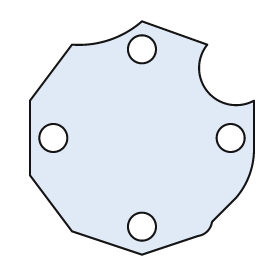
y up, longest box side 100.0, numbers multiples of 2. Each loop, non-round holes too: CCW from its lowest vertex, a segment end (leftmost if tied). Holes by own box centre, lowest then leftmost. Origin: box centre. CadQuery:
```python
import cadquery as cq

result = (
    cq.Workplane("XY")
    .moveTo(0.0, -50.0)
    .lineTo(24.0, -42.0)
    .threePointArc((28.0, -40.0), (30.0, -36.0))
    .lineTo(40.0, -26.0)
    .threePointArc((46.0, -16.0), (48.0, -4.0))
    .lineTo(48.0, 16.0)
    .threePointArc((28.0, 20.0), (28.0, 40.0))
    .lineTo(0.0, 50.0)
    .threePointArc((-14.0, 42.0), (-30.0, 40.0))
    .lineTo(-48.0, 16.0)
    .lineTo(-48.0, -16.0)
    .lineTo(-30.0, -40.0)
    .close()
    .moveTo(0.0, -38.0)
    .circle(6.0)
    .moveTo(-38.0, 0.0)
    .circle(6.0)
    .moveTo(38.0, 0.0)
    .circle(6.0)
    .moveTo(0.0, 38.0)
    .circle(6.0)
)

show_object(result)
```